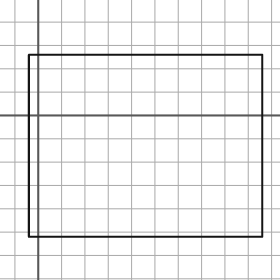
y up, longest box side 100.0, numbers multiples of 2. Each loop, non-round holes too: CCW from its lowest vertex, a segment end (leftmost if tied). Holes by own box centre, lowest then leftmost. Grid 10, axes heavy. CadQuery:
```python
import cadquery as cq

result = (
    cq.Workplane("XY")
    .moveTo(-4.0, -52.0)
    .lineTo(96.0, -52.0)
    .lineTo(96.0, 26.0)
    .lineTo(-4.0, 26.0)
    .close()
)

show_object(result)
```